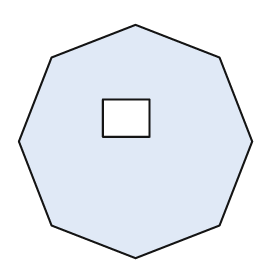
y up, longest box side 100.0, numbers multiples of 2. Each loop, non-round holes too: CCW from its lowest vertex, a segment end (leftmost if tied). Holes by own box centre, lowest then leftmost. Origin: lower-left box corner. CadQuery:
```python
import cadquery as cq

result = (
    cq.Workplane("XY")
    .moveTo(50.0, 0.0)
    .lineTo(86.0, 14.0)
    .lineTo(100.0, 50.0)
    .lineTo(86.0, 86.0)
    .lineTo(50.0, 100.0)
    .lineTo(14.0, 86.0)
    .lineTo(0.0, 50.0)
    .lineTo(14.0, 14.0)
    .close()
    .moveTo(36.0, 52.0)
    .lineTo(56.0, 52.0)
    .lineTo(56.0, 68.0)
    .lineTo(36.0, 68.0)
    .close()
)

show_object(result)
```